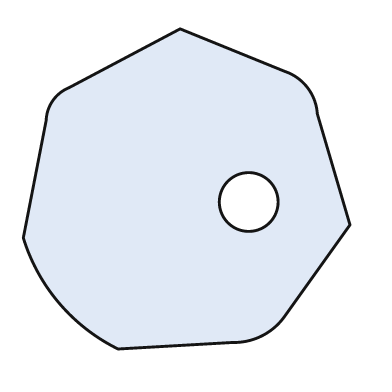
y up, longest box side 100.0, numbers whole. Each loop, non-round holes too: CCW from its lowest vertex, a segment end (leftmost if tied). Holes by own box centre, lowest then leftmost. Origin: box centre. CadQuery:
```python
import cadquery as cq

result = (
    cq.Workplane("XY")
    .moveTo(-21.0, -49.0)
    .lineTo(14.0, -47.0)
    .threePointArc((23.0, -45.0), (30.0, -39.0))
    .lineTo(50.0, -11.0)
    .lineTo(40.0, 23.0)
    .threePointArc((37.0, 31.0), (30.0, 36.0))
    .lineTo(-2.0, 49.0)
    .lineTo(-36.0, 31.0)
    .threePointArc((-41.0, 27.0), (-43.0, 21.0))
    .lineTo(-50.0, -15.0)
    .threePointArc((-39.0, -35.0), (-21.0, -49.0))
    .close()
    .moveTo(19.0, -4.0)
    .circle(9.0)
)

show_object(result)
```